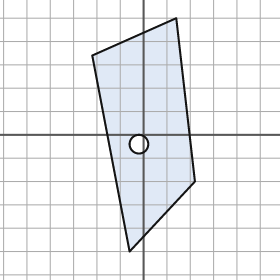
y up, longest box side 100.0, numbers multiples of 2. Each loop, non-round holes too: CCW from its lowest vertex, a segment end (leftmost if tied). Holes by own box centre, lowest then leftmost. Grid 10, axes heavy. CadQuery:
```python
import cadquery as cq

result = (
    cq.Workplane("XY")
    .moveTo(-6.0, -50.0)
    .lineTo(22.0, -20.0)
    .lineTo(14.0, 50.0)
    .lineTo(-22.0, 34.0)
    .close()
    .moveTo(-2.0, -4.0)
    .circle(4.0)
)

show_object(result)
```